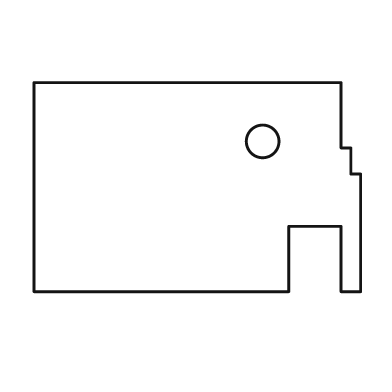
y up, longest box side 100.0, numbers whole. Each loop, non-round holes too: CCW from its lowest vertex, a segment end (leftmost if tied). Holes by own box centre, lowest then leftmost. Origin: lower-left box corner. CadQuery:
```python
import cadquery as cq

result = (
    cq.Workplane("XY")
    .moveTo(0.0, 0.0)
    .lineTo(78.0, 0.0)
    .lineTo(78.0, 20.0)
    .lineTo(94.0, 20.0)
    .lineTo(94.0, 0.0)
    .lineTo(100.0, 0.0)
    .lineTo(100.0, 36.0)
    .lineTo(97.0, 36.0)
    .lineTo(97.0, 44.0)
    .lineTo(94.0, 44.0)
    .lineTo(94.0, 64.0)
    .lineTo(0.0, 64.0)
    .close()
    .moveTo(70.0, 46.0)
    .circle(5.0)
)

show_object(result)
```